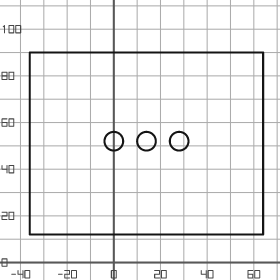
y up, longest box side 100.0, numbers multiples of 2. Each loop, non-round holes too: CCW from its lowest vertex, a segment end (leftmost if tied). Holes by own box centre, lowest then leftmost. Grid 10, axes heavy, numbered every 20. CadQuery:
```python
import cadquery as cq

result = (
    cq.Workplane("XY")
    .moveTo(-36.0, 12.0)
    .lineTo(64.0, 12.0)
    .lineTo(64.0, 90.0)
    .lineTo(-36.0, 90.0)
    .close()
    .moveTo(0.0, 52.0)
    .circle(4.0)
    .moveTo(14.0, 52.0)
    .circle(4.0)
    .moveTo(28.0, 52.0)
    .circle(4.0)
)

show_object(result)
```